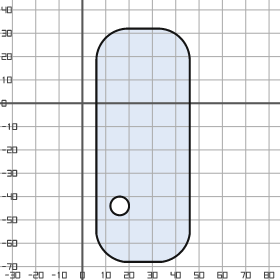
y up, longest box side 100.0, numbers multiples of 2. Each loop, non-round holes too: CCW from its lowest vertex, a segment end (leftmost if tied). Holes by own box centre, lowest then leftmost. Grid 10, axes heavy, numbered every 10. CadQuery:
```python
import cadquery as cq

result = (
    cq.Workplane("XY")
    .moveTo(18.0, -68.0)
    .lineTo(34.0, -68.0)
    .threePointArc((42.0, -64.0), (46.0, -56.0))
    .lineTo(46.0, 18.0)
    .threePointArc((42.0, 28.0), (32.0, 32.0))
    .lineTo(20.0, 32.0)
    .threePointArc((10.0, 28.0), (6.0, 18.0))
    .lineTo(6.0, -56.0)
    .threePointArc((10.0, -64.0), (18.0, -68.0))
    .close()
    .moveTo(16.0, -44.0)
    .circle(4.0)
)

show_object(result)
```